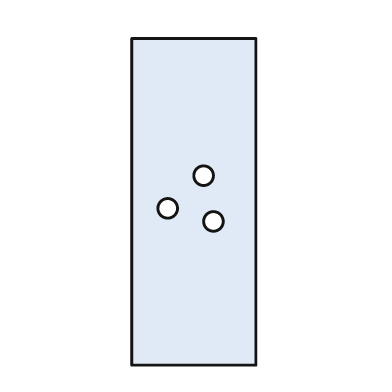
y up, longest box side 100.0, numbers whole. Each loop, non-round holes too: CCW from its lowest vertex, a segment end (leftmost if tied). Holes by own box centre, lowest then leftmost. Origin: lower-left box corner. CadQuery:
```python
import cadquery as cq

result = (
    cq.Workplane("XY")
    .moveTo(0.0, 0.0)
    .lineTo(38.0, 0.0)
    .lineTo(38.0, 100.0)
    .lineTo(0.0, 100.0)
    .close()
    .moveTo(25.0, 44.0)
    .circle(3.0)
    .moveTo(11.0, 48.0)
    .circle(3.0)
    .moveTo(22.0, 58.0)
    .circle(3.0)
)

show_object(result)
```